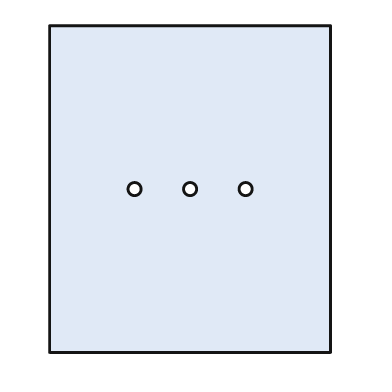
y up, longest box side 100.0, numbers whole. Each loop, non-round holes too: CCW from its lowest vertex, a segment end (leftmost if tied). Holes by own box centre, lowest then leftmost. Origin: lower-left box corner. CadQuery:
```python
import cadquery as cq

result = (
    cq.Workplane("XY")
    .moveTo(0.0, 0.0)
    .lineTo(86.0, 0.0)
    .lineTo(86.0, 100.0)
    .lineTo(0.0, 100.0)
    .close()
    .moveTo(26.0, 50.0)
    .circle(2.0)
    .moveTo(43.0, 50.0)
    .circle(2.0)
    .moveTo(60.0, 50.0)
    .circle(2.0)
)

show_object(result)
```